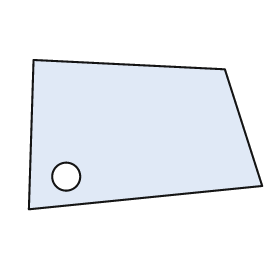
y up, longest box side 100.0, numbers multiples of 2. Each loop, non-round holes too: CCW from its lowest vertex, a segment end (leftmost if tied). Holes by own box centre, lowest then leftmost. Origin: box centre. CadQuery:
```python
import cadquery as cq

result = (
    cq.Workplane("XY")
    .moveTo(-50.0, -32.0)
    .lineTo(50.0, -22.0)
    .lineTo(34.0, 28.0)
    .lineTo(-48.0, 32.0)
    .close()
    .moveTo(-34.0, -18.0)
    .circle(6.0)
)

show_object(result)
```